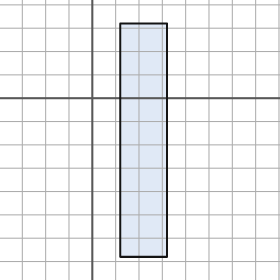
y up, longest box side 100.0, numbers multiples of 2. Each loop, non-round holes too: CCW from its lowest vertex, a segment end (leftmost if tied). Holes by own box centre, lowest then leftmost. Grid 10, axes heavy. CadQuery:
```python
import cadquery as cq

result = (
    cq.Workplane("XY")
    .moveTo(12.0, -68.0)
    .lineTo(32.0, -68.0)
    .lineTo(32.0, 32.0)
    .lineTo(12.0, 32.0)
    .close()
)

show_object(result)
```